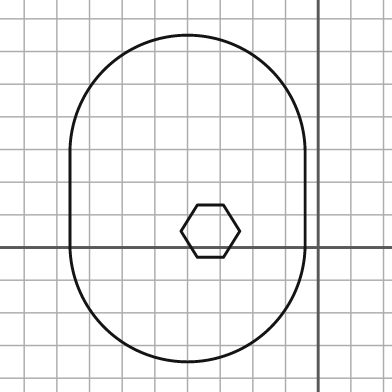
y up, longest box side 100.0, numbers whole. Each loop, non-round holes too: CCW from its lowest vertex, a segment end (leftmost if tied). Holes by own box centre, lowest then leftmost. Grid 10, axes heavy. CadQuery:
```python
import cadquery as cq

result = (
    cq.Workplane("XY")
    .moveTo(-76.0, 1.0)
    .threePointArc((-40.0, -35.0), (-4.0, 1.0))
    .lineTo(-4.0, 29.0)
    .threePointArc((-40.0, 65.0), (-76.0, 29.0))
    .close()
    .moveTo(-37.0, -3.0)
    .lineTo(-29.0, -3.0)
    .lineTo(-24.0, 5.0)
    .lineTo(-29.0, 13.0)
    .lineTo(-37.0, 13.0)
    .lineTo(-42.0, 5.0)
    .close()
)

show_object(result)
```